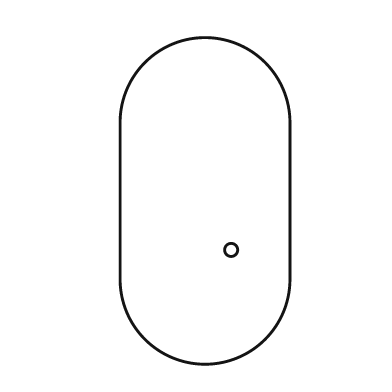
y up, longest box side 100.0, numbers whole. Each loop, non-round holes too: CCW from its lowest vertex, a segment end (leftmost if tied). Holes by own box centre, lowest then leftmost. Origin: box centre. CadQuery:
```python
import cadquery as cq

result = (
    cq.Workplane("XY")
    .moveTo(-26.0, -24.0)
    .threePointArc((0.0, -50.0), (26.0, -24.0))
    .lineTo(26.0, 24.0)
    .threePointArc((0.0, 50.0), (-26.0, 24.0))
    .close()
    .moveTo(8.0, -15.0)
    .circle(2.0)
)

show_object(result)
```